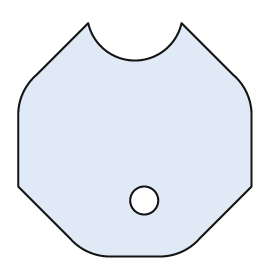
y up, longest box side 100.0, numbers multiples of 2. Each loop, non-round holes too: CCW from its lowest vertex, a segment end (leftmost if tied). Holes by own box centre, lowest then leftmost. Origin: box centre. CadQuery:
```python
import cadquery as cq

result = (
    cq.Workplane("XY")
    .moveTo(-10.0, -50.0)
    .lineTo(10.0, -50.0)
    .threePointArc((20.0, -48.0), (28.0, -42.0))
    .lineTo(50.0, -20.0)
    .lineTo(50.0, 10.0)
    .threePointArc((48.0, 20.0), (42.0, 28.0))
    .lineTo(20.0, 50.0)
    .threePointArc((0.0, 34.0), (-20.0, 50.0))
    .lineTo(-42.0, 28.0)
    .threePointArc((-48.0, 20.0), (-50.0, 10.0))
    .lineTo(-50.0, -20.0)
    .lineTo(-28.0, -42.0)
    .threePointArc((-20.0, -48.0), (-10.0, -50.0))
    .close()
    .moveTo(4.0, -26.0)
    .circle(6.0)
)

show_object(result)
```